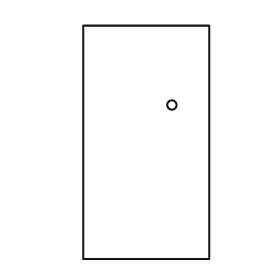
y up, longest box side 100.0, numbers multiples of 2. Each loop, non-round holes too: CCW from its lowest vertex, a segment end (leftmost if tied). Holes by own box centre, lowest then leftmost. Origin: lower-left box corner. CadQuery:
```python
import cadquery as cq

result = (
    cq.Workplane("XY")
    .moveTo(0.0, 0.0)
    .lineTo(54.0, 0.0)
    .lineTo(54.0, 100.0)
    .lineTo(0.0, 100.0)
    .close()
    .moveTo(38.0, 66.0)
    .circle(2.0)
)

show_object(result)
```